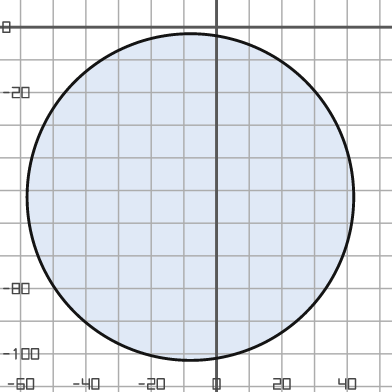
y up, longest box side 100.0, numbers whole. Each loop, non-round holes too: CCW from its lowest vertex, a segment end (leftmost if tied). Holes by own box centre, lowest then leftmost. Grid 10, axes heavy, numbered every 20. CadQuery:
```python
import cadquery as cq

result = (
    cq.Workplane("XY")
    .moveTo(-8.0, -52.0)
    .circle(50.0)
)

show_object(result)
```